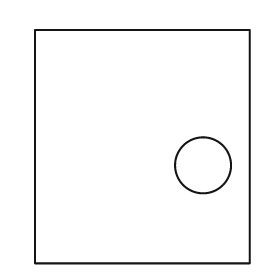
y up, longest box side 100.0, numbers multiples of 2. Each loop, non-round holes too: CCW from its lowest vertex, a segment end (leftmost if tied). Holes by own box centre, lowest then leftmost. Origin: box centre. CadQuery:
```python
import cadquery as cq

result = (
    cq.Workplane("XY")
    .moveTo(-46.0, -50.0)
    .lineTo(46.0, -50.0)
    .lineTo(46.0, 50.0)
    .lineTo(-46.0, 50.0)
    .close()
    .moveTo(26.0, -8.0)
    .circle(12.0)
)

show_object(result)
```